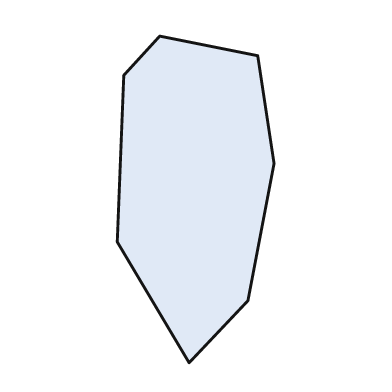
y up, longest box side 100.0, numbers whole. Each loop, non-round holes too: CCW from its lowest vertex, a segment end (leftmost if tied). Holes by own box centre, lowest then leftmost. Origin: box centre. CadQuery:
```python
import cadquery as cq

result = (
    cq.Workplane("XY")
    .moveTo(-2.0, -50.0)
    .lineTo(16.0, -31.0)
    .lineTo(24.0, 11.0)
    .lineTo(19.0, 44.0)
    .lineTo(-11.0, 50.0)
    .lineTo(-22.0, 38.0)
    .lineTo(-24.0, -13.0)
    .close()
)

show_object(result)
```